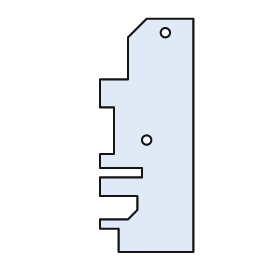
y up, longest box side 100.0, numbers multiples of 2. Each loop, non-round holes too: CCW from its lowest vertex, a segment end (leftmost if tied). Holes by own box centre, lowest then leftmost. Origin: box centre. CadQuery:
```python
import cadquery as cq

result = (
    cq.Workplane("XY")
    .moveTo(-12.0, -50.0)
    .lineTo(20.0, -50.0)
    .lineTo(20.0, 50.0)
    .lineTo(0.0, 50.0)
    .lineTo(-8.0, 42.0)
    .lineTo(-8.0, 24.0)
    .lineTo(-20.0, 24.0)
    .lineTo(-20.0, 12.0)
    .lineTo(-14.0, 12.0)
    .lineTo(-14.0, -8.0)
    .lineTo(-20.0, -8.0)
    .lineTo(-20.0, -14.0)
    .lineTo(-2.0, -14.0)
    .lineTo(-2.0, -18.0)
    .lineTo(-20.0, -18.0)
    .lineTo(-20.0, -26.0)
    .lineTo(-4.0, -26.0)
    .lineTo(-4.0, -32.0)
    .lineTo(-8.0, -36.0)
    .lineTo(-20.0, -36.0)
    .lineTo(-20.0, -40.0)
    .lineTo(-12.0, -40.0)
    .close()
    .moveTo(0.0, -2.0)
    .circle(2.0)
    .moveTo(8.0, 44.0)
    .circle(2.0)
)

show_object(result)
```